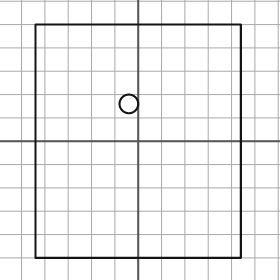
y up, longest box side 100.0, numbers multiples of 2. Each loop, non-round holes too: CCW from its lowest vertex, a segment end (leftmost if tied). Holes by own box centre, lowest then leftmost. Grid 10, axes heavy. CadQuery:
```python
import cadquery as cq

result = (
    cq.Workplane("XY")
    .moveTo(-44.0, -50.0)
    .lineTo(44.0, -50.0)
    .lineTo(44.0, 50.0)
    .lineTo(-44.0, 50.0)
    .close()
    .moveTo(-4.0, 16.0)
    .circle(4.0)
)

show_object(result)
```